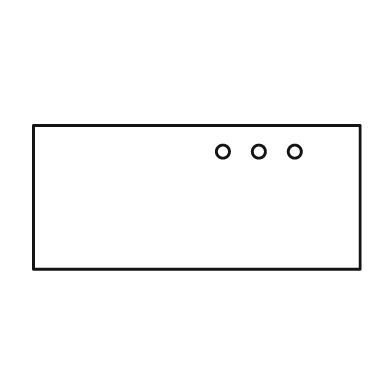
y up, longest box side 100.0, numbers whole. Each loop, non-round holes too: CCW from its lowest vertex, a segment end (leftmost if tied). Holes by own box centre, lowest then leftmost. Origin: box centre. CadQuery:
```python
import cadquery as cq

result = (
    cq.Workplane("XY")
    .moveTo(-50.0, -22.0)
    .lineTo(50.0, -22.0)
    .lineTo(50.0, 22.0)
    .lineTo(-50.0, 22.0)
    .close()
    .moveTo(8.0, 14.0)
    .circle(2.0)
    .moveTo(19.0, 14.0)
    .circle(2.0)
    .moveTo(30.0, 14.0)
    .circle(2.0)
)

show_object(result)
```